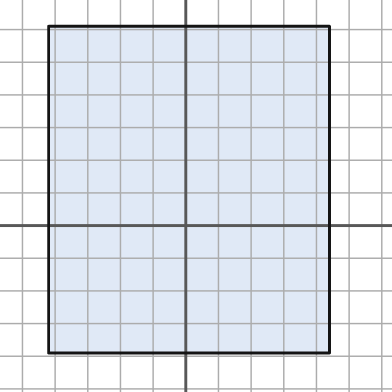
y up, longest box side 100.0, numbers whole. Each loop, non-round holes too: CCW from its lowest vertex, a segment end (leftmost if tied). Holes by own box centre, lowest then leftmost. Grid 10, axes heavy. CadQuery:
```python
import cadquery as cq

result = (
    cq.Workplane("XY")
    .moveTo(-42.0, -39.0)
    .lineTo(44.0, -39.0)
    .lineTo(44.0, 61.0)
    .lineTo(-42.0, 61.0)
    .close()
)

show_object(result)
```